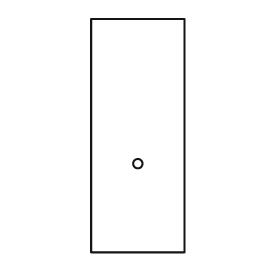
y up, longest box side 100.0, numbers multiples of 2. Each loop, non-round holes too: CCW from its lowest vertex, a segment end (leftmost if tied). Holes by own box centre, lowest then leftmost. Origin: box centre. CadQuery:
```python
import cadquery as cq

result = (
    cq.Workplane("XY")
    .moveTo(-20.0, -50.0)
    .lineTo(20.0, -50.0)
    .lineTo(20.0, 50.0)
    .lineTo(-20.0, 50.0)
    .close()
    .moveTo(0.0, -12.0)
    .circle(2.0)
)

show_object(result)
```